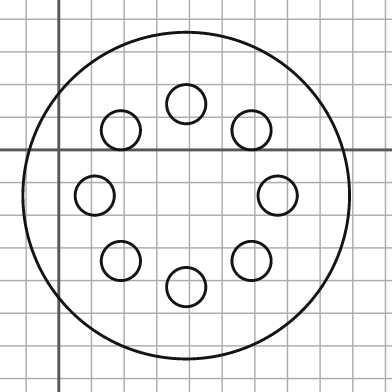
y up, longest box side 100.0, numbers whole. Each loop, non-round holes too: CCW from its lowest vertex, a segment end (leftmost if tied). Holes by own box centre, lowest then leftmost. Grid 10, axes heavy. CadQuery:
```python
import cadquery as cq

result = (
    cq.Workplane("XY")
    .moveTo(39.0, -14.0)
    .circle(50.0)
    .moveTo(39.0, -42.0)
    .circle(6.0)
    .moveTo(19.0, -34.0)
    .circle(6.0)
    .moveTo(59.0, -34.0)
    .circle(6.0)
    .moveTo(11.0, -14.0)
    .circle(6.0)
    .moveTo(67.0, -14.0)
    .circle(6.0)
    .moveTo(19.0, 6.0)
    .circle(6.0)
    .moveTo(59.0, 6.0)
    .circle(6.0)
    .moveTo(39.0, 14.0)
    .circle(6.0)
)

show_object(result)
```